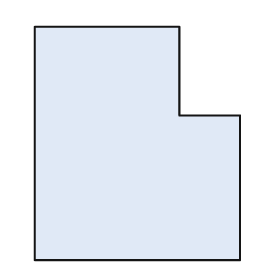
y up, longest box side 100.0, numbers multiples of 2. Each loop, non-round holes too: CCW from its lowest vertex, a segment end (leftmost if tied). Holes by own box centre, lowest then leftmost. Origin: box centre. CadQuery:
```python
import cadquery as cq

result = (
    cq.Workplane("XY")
    .moveTo(-44.0, -50.0)
    .lineTo(44.0, -50.0)
    .lineTo(44.0, 12.0)
    .lineTo(18.0, 12.0)
    .lineTo(18.0, 50.0)
    .lineTo(-44.0, 50.0)
    .close()
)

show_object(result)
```